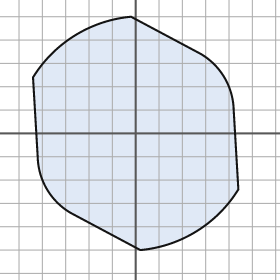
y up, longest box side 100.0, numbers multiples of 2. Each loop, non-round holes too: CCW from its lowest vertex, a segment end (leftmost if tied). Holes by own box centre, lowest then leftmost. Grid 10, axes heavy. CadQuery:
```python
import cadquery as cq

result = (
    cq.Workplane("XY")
    .moveTo(2.0, -50.0)
    .threePointArc((26.0, -42.0), (44.0, -24.0))
    .lineTo(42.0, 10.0)
    .threePointArc((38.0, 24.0), (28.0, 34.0))
    .lineTo(-2.0, 50.0)
    .threePointArc((-26.0, 42.0), (-44.0, 24.0))
    .lineTo(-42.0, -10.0)
    .threePointArc((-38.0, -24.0), (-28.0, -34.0))
    .close()
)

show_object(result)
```